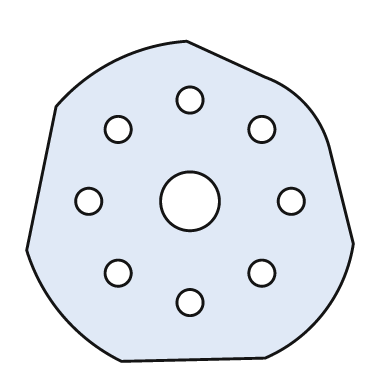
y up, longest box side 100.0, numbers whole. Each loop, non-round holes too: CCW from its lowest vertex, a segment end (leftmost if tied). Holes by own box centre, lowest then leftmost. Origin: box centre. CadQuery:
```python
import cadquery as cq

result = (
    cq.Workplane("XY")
    .moveTo(-21.0, -49.0)
    .lineTo(23.0, -48.0)
    .threePointArc((41.0, -34.0), (50.0, -13.0))
    .lineTo(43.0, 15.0)
    .threePointArc((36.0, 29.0), (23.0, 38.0))
    .lineTo(-1.0, 49.0)
    .threePointArc((-23.0, 43.0), (-41.0, 29.0))
    .lineTo(-50.0, -15.0)
    .threePointArc((-39.0, -35.0), (-21.0, -49.0))
    .close()
    .moveTo(0.0, -31.0)
    .circle(4.0)
    .moveTo(-22.0, -22.0)
    .circle(4.0)
    .moveTo(22.0, -22.0)
    .circle(4.0)
    .moveTo(-31.0, 0.0)
    .circle(4.0)
    .moveTo(0.0, 0.0)
    .circle(9.0)
    .moveTo(31.0, 0.0)
    .circle(4.0)
    .moveTo(-22.0, 22.0)
    .circle(4.0)
    .moveTo(22.0, 22.0)
    .circle(4.0)
    .moveTo(0.0, 31.0)
    .circle(4.0)
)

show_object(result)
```